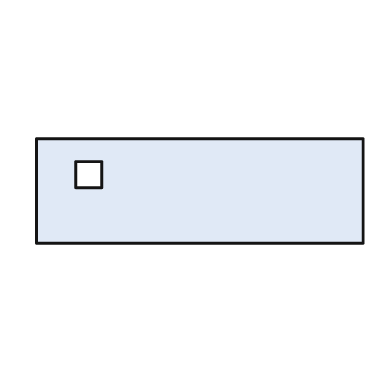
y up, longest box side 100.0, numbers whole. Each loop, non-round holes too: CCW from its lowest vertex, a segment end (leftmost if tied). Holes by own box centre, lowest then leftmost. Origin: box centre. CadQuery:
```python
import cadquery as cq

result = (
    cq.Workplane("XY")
    .moveTo(-50.0, -16.0)
    .lineTo(50.0, -16.0)
    .lineTo(50.0, 16.0)
    .lineTo(-50.0, 16.0)
    .close()
    .moveTo(-38.0, 1.0)
    .lineTo(-30.0, 1.0)
    .lineTo(-30.0, 9.0)
    .lineTo(-38.0, 9.0)
    .close()
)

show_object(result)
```